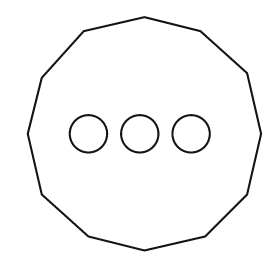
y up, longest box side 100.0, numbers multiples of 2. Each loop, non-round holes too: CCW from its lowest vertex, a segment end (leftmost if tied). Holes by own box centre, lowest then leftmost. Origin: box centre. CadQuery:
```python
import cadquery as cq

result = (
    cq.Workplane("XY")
    .moveTo(0.0, -50.0)
    .lineTo(26.0, -44.0)
    .lineTo(44.0, -26.0)
    .lineTo(50.0, 0.0)
    .lineTo(44.0, 26.0)
    .lineTo(24.0, 44.0)
    .lineTo(0.0, 50.0)
    .lineTo(-26.0, 44.0)
    .lineTo(-44.0, 24.0)
    .lineTo(-50.0, 0.0)
    .lineTo(-44.0, -26.0)
    .lineTo(-24.0, -44.0)
    .close()
    .moveTo(-24.0, 0.0)
    .circle(8.0)
    .moveTo(-2.0, 0.0)
    .circle(8.0)
    .moveTo(20.0, 0.0)
    .circle(8.0)
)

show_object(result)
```